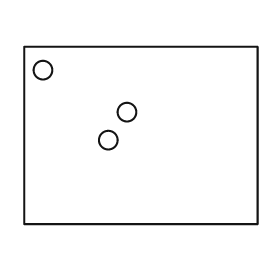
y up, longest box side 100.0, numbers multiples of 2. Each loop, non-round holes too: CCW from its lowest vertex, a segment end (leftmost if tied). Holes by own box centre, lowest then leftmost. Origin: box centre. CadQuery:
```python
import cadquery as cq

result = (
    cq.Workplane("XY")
    .moveTo(-50.0, -38.0)
    .lineTo(50.0, -38.0)
    .lineTo(50.0, 38.0)
    .lineTo(-50.0, 38.0)
    .close()
    .moveTo(-14.0, -2.0)
    .circle(4.0)
    .moveTo(-6.0, 10.0)
    .circle(4.0)
    .moveTo(-42.0, 28.0)
    .circle(4.0)
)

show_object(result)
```